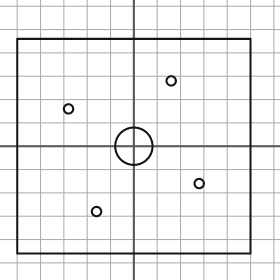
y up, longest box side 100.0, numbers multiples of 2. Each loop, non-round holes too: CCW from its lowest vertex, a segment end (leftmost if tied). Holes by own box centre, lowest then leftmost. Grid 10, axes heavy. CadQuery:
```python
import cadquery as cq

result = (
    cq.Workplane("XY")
    .moveTo(-50.0, -46.0)
    .lineTo(50.0, -46.0)
    .lineTo(50.0, 46.0)
    .lineTo(-50.0, 46.0)
    .close()
    .moveTo(-16.0, -28.0)
    .circle(2.0)
    .moveTo(28.0, -16.0)
    .circle(2.0)
    .moveTo(0.0, 0.0)
    .circle(8.0)
    .moveTo(-28.0, 16.0)
    .circle(2.0)
    .moveTo(16.0, 28.0)
    .circle(2.0)
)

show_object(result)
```